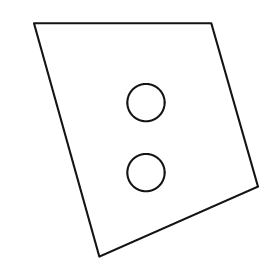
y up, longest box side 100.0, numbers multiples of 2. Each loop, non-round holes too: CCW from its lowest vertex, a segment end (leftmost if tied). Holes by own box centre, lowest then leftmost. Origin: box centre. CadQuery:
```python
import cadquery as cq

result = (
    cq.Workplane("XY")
    .moveTo(-20.0, -50.0)
    .lineTo(48.0, -20.0)
    .lineTo(28.0, 50.0)
    .lineTo(-48.0, 50.0)
    .close()
    .moveTo(0.0, -14.0)
    .circle(8.0)
    .moveTo(0.0, 16.0)
    .circle(8.0)
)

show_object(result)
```